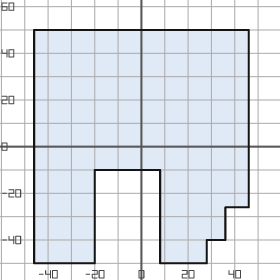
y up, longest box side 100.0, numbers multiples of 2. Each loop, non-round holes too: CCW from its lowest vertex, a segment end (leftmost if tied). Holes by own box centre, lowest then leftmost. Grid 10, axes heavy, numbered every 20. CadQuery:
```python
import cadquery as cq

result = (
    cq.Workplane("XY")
    .moveTo(-46.0, -50.0)
    .lineTo(-20.0, -50.0)
    .lineTo(-20.0, -10.0)
    .lineTo(8.0, -10.0)
    .lineTo(8.0, -50.0)
    .lineTo(28.0, -50.0)
    .lineTo(28.0, -40.0)
    .lineTo(36.0, -40.0)
    .lineTo(36.0, -26.0)
    .lineTo(46.0, -26.0)
    .lineTo(46.0, 50.0)
    .lineTo(-46.0, 50.0)
    .close()
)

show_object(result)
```